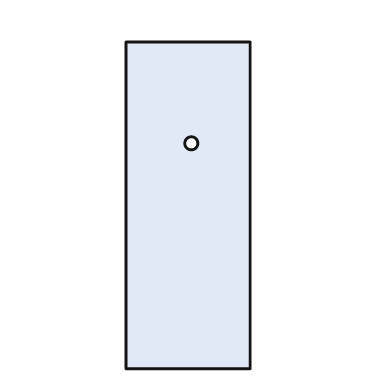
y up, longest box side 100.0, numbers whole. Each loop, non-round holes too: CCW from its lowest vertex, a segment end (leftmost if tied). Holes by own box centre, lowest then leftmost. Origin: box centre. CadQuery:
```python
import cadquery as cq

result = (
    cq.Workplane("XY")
    .moveTo(-19.0, -50.0)
    .lineTo(19.0, -50.0)
    .lineTo(19.0, 50.0)
    .lineTo(-19.0, 50.0)
    .close()
    .moveTo(1.0, 19.0)
    .circle(2.0)
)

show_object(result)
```